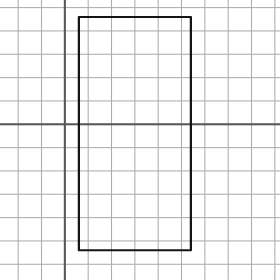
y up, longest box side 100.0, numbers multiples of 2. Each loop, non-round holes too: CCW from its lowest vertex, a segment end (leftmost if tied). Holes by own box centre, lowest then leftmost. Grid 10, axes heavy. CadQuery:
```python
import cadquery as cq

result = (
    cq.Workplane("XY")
    .moveTo(6.0, -54.0)
    .lineTo(54.0, -54.0)
    .lineTo(54.0, 46.0)
    .lineTo(6.0, 46.0)
    .close()
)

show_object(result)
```